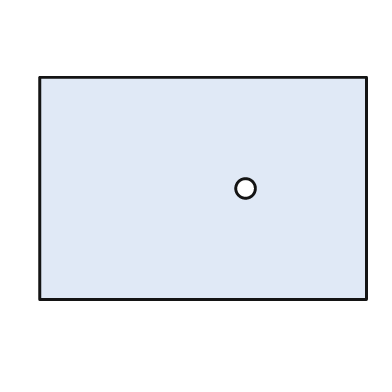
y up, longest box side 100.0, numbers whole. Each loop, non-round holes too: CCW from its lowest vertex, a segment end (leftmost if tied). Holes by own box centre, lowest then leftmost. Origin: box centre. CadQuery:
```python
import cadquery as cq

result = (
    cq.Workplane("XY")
    .moveTo(-50.0, -34.0)
    .lineTo(50.0, -34.0)
    .lineTo(50.0, 34.0)
    .lineTo(-50.0, 34.0)
    .close()
    .moveTo(13.0, 0.0)
    .circle(3.0)
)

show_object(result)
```